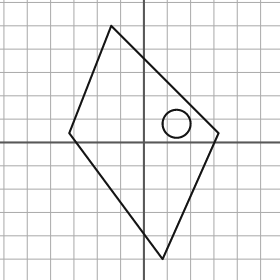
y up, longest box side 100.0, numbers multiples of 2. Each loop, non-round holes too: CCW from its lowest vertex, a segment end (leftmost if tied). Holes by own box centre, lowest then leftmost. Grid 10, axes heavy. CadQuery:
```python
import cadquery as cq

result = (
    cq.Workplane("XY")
    .moveTo(8.0, -50.0)
    .lineTo(32.0, 4.0)
    .lineTo(-14.0, 50.0)
    .lineTo(-32.0, 4.0)
    .close()
    .moveTo(14.0, 8.0)
    .circle(6.0)
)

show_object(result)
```